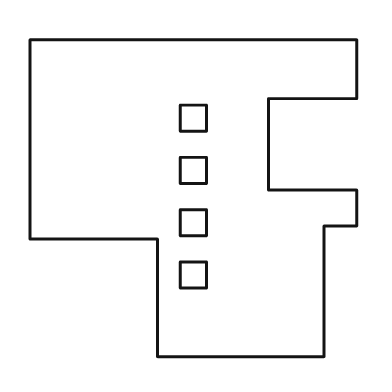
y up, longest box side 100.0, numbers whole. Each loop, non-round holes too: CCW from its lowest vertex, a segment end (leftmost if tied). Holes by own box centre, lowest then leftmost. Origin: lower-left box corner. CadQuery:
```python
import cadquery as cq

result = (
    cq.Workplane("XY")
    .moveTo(39.0, 0.0)
    .lineTo(90.0, 0.0)
    .lineTo(90.0, 40.0)
    .lineTo(100.0, 40.0)
    .lineTo(100.0, 51.0)
    .lineTo(73.0, 51.0)
    .lineTo(73.0, 79.0)
    .lineTo(100.0, 79.0)
    .lineTo(100.0, 97.0)
    .lineTo(0.0, 97.0)
    .lineTo(0.0, 36.0)
    .lineTo(39.0, 36.0)
    .close()
    .moveTo(46.0, 21.0)
    .lineTo(54.0, 21.0)
    .lineTo(54.0, 29.0)
    .lineTo(46.0, 29.0)
    .close()
    .moveTo(46.0, 37.0)
    .lineTo(54.0, 37.0)
    .lineTo(54.0, 45.0)
    .lineTo(46.0, 45.0)
    .close()
    .moveTo(46.0, 53.0)
    .lineTo(54.0, 53.0)
    .lineTo(54.0, 61.0)
    .lineTo(46.0, 61.0)
    .close()
    .moveTo(46.0, 69.0)
    .lineTo(54.0, 69.0)
    .lineTo(54.0, 77.0)
    .lineTo(46.0, 77.0)
    .close()
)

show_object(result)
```